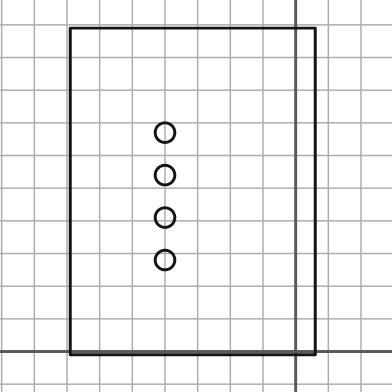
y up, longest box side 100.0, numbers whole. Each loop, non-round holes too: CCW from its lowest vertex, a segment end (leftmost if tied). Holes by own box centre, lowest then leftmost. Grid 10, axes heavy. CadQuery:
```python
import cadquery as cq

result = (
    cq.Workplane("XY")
    .moveTo(-69.0, -1.0)
    .lineTo(6.0, -1.0)
    .lineTo(6.0, 99.0)
    .lineTo(-69.0, 99.0)
    .close()
    .moveTo(-40.0, 28.0)
    .circle(3.0)
    .moveTo(-40.0, 41.0)
    .circle(3.0)
    .moveTo(-40.0, 54.0)
    .circle(3.0)
    .moveTo(-40.0, 67.0)
    .circle(3.0)
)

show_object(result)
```